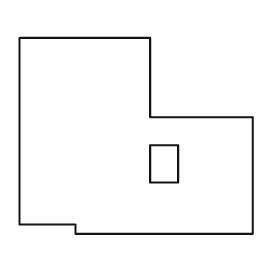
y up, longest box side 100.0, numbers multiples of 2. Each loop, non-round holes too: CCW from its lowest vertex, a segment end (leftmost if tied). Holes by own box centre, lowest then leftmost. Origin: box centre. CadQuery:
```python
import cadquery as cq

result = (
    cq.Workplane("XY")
    .moveTo(-26.0, -42.0)
    .lineTo(50.0, -42.0)
    .lineTo(50.0, 8.0)
    .lineTo(6.0, 8.0)
    .lineTo(6.0, 42.0)
    .lineTo(-50.0, 42.0)
    .lineTo(-50.0, -38.0)
    .lineTo(-26.0, -38.0)
    .close()
    .moveTo(6.0, -20.0)
    .lineTo(18.0, -20.0)
    .lineTo(18.0, -4.0)
    .lineTo(6.0, -4.0)
    .close()
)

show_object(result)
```